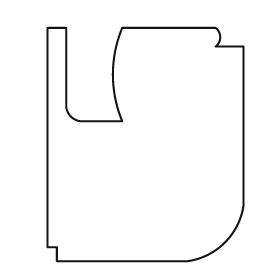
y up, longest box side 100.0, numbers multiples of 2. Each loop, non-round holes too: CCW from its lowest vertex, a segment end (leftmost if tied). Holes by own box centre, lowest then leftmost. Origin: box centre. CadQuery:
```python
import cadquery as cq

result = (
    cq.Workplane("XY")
    .moveTo(-38.0, -50.0)
    .lineTo(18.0, -50.0)
    .threePointArc((34.0, -42.0), (42.0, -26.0))
    .lineTo(42.0, 42.0)
    .lineTo(30.0, 42.0)
    .threePointArc((32.0, 46.0), (30.0, 50.0))
    .lineTo(-10.0, 50.0)
    .threePointArc((-14.0, 30.0), (-10.0, 10.0))
    .lineTo(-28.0, 10.0)
    .threePointArc((-32.0, 12.0), (-34.0, 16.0))
    .lineTo(-34.0, 50.0)
    .lineTo(-42.0, 50.0)
    .lineTo(-42.0, -44.0)
    .lineTo(-38.0, -44.0)
    .close()
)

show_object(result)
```